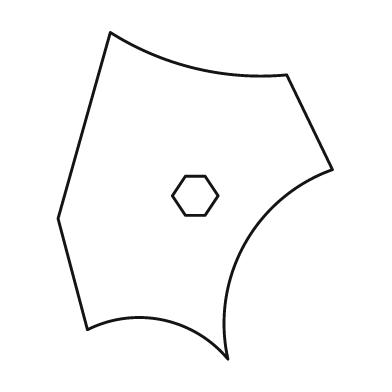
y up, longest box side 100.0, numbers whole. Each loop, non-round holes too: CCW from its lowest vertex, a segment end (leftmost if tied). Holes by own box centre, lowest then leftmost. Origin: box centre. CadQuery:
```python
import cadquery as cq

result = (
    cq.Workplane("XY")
    .moveTo(10.0, -50.0)
    .threePointArc((15.0, -15.0), (42.0, 8.0))
    .lineTo(28.0, 37.0)
    .threePointArc((0.0, 39.0), (-26.0, 50.0))
    .lineTo(-42.0, -7.0)
    .lineTo(-33.0, -41.0)
    .threePointArc((-10.0, -38.0), (10.0, -50.0))
    .close()
    .moveTo(-3.0, -6.0)
    .lineTo(3.0, -6.0)
    .lineTo(7.0, 0.0)
    .lineTo(3.0, 6.0)
    .lineTo(-3.0, 6.0)
    .lineTo(-7.0, 0.0)
    .close()
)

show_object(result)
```